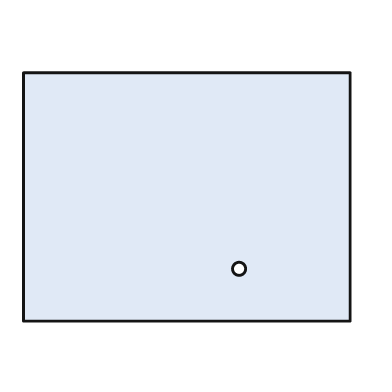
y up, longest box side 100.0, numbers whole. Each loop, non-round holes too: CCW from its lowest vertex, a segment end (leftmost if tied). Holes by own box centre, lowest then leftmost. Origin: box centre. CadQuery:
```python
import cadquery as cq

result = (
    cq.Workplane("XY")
    .moveTo(-50.0, -38.0)
    .lineTo(50.0, -38.0)
    .lineTo(50.0, 38.0)
    .lineTo(-50.0, 38.0)
    .close()
    .moveTo(16.0, -22.0)
    .circle(2.0)
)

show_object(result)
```